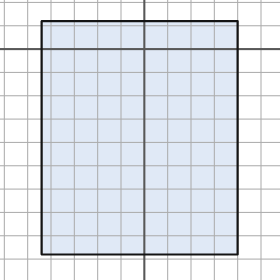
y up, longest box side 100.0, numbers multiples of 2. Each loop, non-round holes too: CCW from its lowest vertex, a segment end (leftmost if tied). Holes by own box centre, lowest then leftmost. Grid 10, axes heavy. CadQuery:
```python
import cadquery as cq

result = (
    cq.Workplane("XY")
    .moveTo(-44.0, -88.0)
    .lineTo(40.0, -88.0)
    .lineTo(40.0, 12.0)
    .lineTo(-44.0, 12.0)
    .close()
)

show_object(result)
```